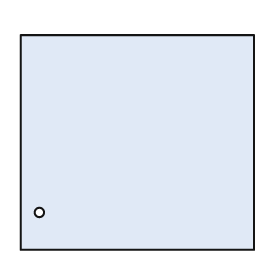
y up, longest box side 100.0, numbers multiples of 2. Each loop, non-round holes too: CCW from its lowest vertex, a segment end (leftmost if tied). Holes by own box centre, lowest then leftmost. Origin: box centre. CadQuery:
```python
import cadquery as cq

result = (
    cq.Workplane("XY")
    .moveTo(-50.0, -46.0)
    .lineTo(50.0, -46.0)
    .lineTo(50.0, 46.0)
    .lineTo(-50.0, 46.0)
    .close()
    .moveTo(-42.0, -30.0)
    .circle(2.0)
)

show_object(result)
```